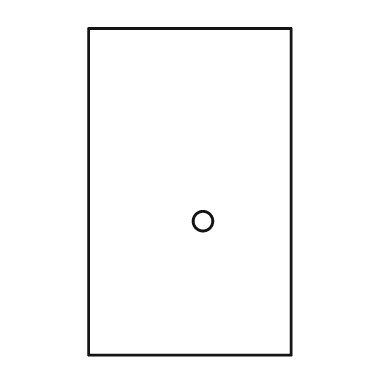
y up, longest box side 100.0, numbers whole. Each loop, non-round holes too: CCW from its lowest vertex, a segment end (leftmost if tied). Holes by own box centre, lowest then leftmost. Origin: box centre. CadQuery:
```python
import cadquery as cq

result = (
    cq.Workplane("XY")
    .moveTo(-31.0, -50.0)
    .lineTo(31.0, -50.0)
    .lineTo(31.0, 50.0)
    .lineTo(-31.0, 50.0)
    .close()
    .moveTo(4.0, -9.0)
    .circle(3.0)
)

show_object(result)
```